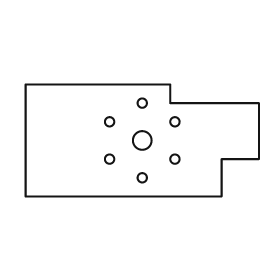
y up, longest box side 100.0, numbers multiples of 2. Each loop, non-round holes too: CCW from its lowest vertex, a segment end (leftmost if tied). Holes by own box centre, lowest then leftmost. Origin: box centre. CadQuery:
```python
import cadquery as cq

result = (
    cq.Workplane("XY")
    .moveTo(-50.0, -24.0)
    .lineTo(34.0, -24.0)
    .lineTo(34.0, -8.0)
    .lineTo(50.0, -8.0)
    .lineTo(50.0, 16.0)
    .lineTo(12.0, 16.0)
    .lineTo(12.0, 24.0)
    .lineTo(-50.0, 24.0)
    .close()
    .moveTo(0.0, -16.0)
    .circle(2.0)
    .moveTo(-14.0, -8.0)
    .circle(2.0)
    .moveTo(14.0, -8.0)
    .circle(2.0)
    .moveTo(0.0, 0.0)
    .circle(4.0)
    .moveTo(-14.0, 8.0)
    .circle(2.0)
    .moveTo(14.0, 8.0)
    .circle(2.0)
    .moveTo(0.0, 16.0)
    .circle(2.0)
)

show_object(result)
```